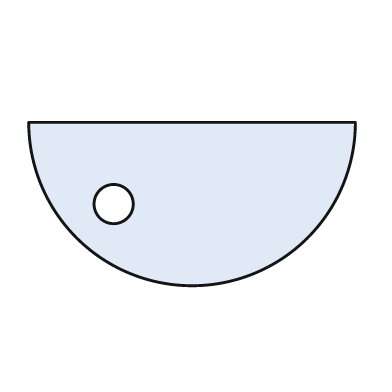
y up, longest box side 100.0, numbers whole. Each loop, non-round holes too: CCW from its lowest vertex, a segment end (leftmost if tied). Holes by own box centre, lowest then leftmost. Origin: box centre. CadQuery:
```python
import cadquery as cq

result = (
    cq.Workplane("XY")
    .moveTo(-50.0, 25.0)
    .threePointArc((0.0, -25.0), (50.0, 25.0))
    .close()
    .moveTo(-24.0, 0.0)
    .circle(6.0)
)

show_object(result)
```